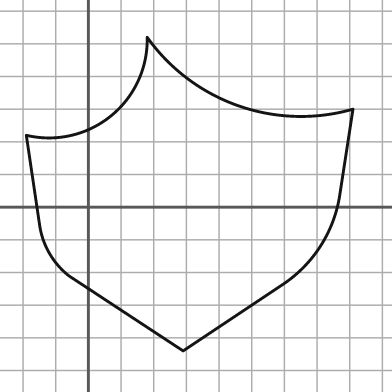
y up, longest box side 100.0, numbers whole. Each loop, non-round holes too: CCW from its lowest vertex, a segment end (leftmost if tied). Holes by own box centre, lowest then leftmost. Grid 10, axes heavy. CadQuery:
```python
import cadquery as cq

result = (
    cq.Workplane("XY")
    .moveTo(29.0, -44.0)
    .lineTo(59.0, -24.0)
    .threePointArc((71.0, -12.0), (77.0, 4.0))
    .lineTo(81.0, 30.0)
    .threePointArc((46.0, 31.0), (18.0, 52.0))
    .threePointArc((7.0, 28.0), (-19.0, 22.0))
    .lineTo(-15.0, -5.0)
    .threePointArc((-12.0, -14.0), (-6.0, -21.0))
    .close()
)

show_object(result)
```